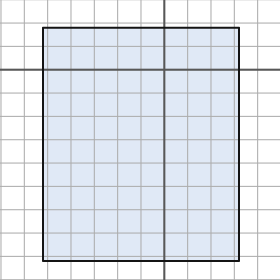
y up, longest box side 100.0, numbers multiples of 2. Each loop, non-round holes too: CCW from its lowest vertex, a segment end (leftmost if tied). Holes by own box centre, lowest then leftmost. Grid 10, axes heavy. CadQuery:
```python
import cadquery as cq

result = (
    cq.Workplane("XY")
    .moveTo(-52.0, -82.0)
    .lineTo(32.0, -82.0)
    .lineTo(32.0, 18.0)
    .lineTo(-52.0, 18.0)
    .close()
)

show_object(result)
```